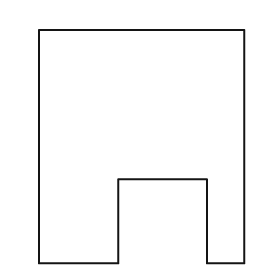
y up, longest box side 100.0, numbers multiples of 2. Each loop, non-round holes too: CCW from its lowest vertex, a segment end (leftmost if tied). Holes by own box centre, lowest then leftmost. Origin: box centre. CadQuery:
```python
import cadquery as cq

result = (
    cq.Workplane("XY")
    .moveTo(-44.0, -50.0)
    .lineTo(-10.0, -50.0)
    .lineTo(-10.0, -14.0)
    .lineTo(28.0, -14.0)
    .lineTo(28.0, -50.0)
    .lineTo(44.0, -50.0)
    .lineTo(44.0, 50.0)
    .lineTo(-44.0, 50.0)
    .close()
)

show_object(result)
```